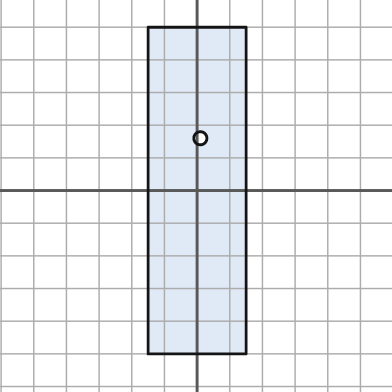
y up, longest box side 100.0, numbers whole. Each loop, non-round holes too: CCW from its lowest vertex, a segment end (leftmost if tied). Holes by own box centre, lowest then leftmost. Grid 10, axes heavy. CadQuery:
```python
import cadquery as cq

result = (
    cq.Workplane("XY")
    .moveTo(-15.0, -50.0)
    .lineTo(15.0, -50.0)
    .lineTo(15.0, 50.0)
    .lineTo(-15.0, 50.0)
    .close()
    .moveTo(1.0, 16.0)
    .circle(2.0)
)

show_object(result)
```